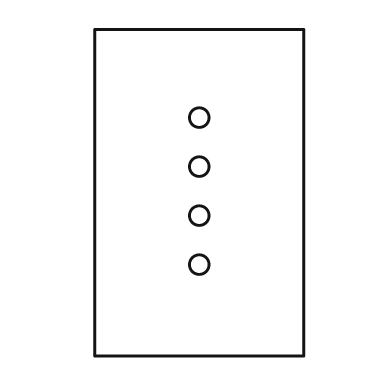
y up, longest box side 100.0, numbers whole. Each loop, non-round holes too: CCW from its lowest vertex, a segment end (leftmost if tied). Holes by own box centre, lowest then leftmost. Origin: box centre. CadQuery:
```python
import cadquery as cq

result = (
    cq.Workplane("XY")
    .moveTo(-32.0, -50.0)
    .lineTo(32.0, -50.0)
    .lineTo(32.0, 50.0)
    .lineTo(-32.0, 50.0)
    .close()
    .moveTo(0.0, -22.0)
    .circle(3.0)
    .moveTo(0.0, -7.0)
    .circle(3.0)
    .moveTo(0.0, 8.0)
    .circle(3.0)
    .moveTo(0.0, 23.0)
    .circle(3.0)
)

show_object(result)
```